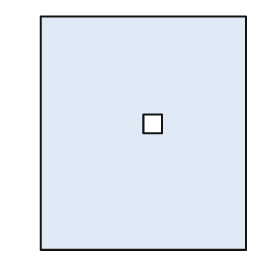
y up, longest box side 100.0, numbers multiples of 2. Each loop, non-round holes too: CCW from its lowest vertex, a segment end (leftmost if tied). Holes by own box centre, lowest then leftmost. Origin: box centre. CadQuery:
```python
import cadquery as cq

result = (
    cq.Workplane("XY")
    .moveTo(-44.0, -50.0)
    .lineTo(44.0, -50.0)
    .lineTo(44.0, 50.0)
    .lineTo(-44.0, 50.0)
    .close()
    .moveTo(0.0, 0.0)
    .lineTo(8.0, 0.0)
    .lineTo(8.0, 8.0)
    .lineTo(0.0, 8.0)
    .close()
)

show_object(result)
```